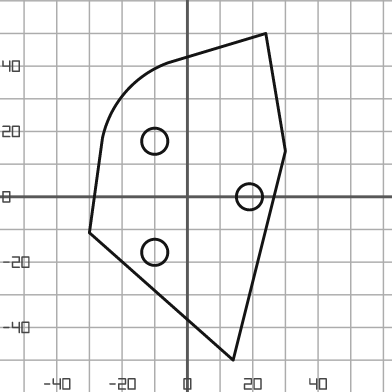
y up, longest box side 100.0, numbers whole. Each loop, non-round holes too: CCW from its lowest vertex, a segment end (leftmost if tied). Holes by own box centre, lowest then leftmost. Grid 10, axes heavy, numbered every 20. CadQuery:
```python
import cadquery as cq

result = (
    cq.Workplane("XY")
    .moveTo(14.0, -50.0)
    .lineTo(30.0, 14.0)
    .lineTo(24.0, 50.0)
    .lineTo(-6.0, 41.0)
    .threePointArc((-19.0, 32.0), (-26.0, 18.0))
    .lineTo(-30.0, -11.0)
    .close()
    .moveTo(-10.0, -17.0)
    .circle(4.0)
    .moveTo(19.0, 0.0)
    .circle(4.0)
    .moveTo(-10.0, 17.0)
    .circle(4.0)
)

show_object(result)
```